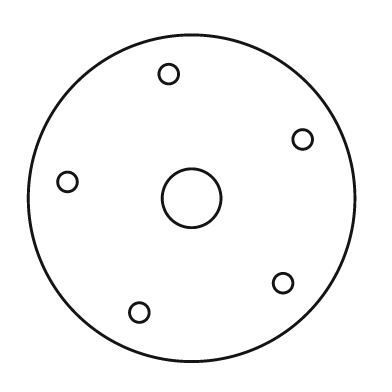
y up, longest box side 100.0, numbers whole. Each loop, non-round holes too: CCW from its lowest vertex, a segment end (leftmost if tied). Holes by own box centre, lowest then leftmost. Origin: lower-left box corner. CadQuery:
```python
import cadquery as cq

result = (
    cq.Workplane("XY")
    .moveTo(50.0, 50.0)
    .circle(50.0)
    .moveTo(34.0, 15.0)
    .circle(3.0)
    .moveTo(78.0, 24.0)
    .circle(3.0)
    .moveTo(50.0, 50.0)
    .circle(9.0)
    .moveTo(12.0, 55.0)
    .circle(3.0)
    .moveTo(84.0, 68.0)
    .circle(3.0)
    .moveTo(43.0, 88.0)
    .circle(3.0)
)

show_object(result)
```